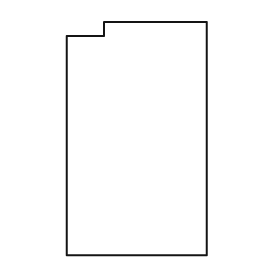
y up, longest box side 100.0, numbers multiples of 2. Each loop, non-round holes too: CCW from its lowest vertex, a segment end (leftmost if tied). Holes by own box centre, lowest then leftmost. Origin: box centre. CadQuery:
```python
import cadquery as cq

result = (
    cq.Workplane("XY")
    .moveTo(-30.0, -50.0)
    .lineTo(30.0, -50.0)
    .lineTo(30.0, 50.0)
    .lineTo(-14.0, 50.0)
    .lineTo(-14.0, 44.0)
    .lineTo(-30.0, 44.0)
    .close()
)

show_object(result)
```